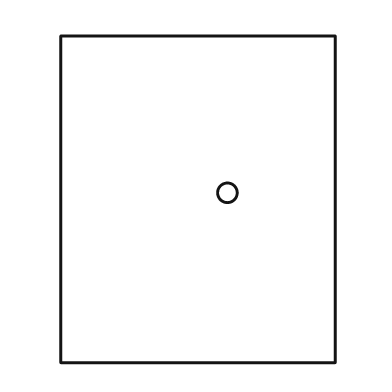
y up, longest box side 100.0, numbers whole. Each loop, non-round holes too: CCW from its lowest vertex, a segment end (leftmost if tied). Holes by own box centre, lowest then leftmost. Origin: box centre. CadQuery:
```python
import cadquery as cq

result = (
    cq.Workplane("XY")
    .moveTo(-42.0, -50.0)
    .lineTo(42.0, -50.0)
    .lineTo(42.0, 50.0)
    .lineTo(-42.0, 50.0)
    .close()
    .moveTo(9.0, 2.0)
    .circle(3.0)
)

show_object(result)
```